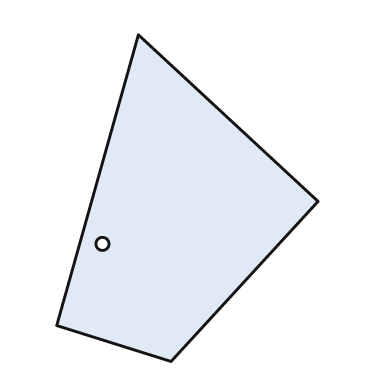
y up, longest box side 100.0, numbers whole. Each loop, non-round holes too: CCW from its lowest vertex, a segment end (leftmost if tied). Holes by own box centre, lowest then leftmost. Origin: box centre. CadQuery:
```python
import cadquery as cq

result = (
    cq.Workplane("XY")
    .moveTo(-5.0, -50.0)
    .lineTo(40.0, -1.0)
    .lineTo(-15.0, 50.0)
    .lineTo(-40.0, -39.0)
    .close()
    .moveTo(-26.0, -14.0)
    .circle(2.0)
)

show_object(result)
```